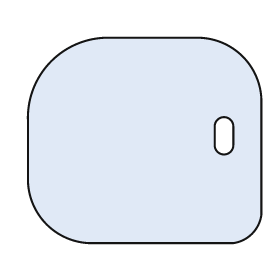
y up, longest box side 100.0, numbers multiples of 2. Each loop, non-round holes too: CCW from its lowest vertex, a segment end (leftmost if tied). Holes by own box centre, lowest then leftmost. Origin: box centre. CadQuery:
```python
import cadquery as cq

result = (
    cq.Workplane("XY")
    .moveTo(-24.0, -44.0)
    .lineTo(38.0, -44.0)
    .threePointArc((46.0, -40.0), (50.0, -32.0))
    .lineTo(50.0, 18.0)
    .threePointArc((42.0, 36.0), (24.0, 44.0))
    .lineTo(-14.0, 44.0)
    .threePointArc((-40.0, 34.0), (-50.0, 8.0))
    .lineTo(-50.0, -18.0)
    .threePointArc((-42.0, -36.0), (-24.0, -44.0))
    .close()
    .moveTo(30.0, -2.0)
    .threePointArc((34.0, -6.0), (38.0, -2.0))
    .lineTo(38.0, 6.0)
    .threePointArc((34.0, 10.0), (30.0, 6.0))
    .close()
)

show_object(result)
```